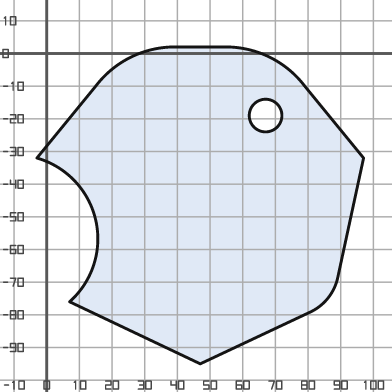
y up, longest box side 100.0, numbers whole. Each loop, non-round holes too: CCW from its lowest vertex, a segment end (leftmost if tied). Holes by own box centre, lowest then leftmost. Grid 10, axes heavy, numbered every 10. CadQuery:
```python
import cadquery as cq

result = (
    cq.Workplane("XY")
    .moveTo(47.0, -95.0)
    .lineTo(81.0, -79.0)
    .threePointArc((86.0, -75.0), (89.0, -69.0))
    .lineTo(97.0, -32.0)
    .lineTo(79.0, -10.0)
    .threePointArc((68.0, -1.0), (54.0, 2.0))
    .lineTo(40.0, 2.0)
    .threePointArc((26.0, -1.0), (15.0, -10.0))
    .lineTo(-3.0, -32.0)
    .threePointArc((15.0, -51.0), (7.0, -76.0))
    .close()
    .moveTo(67.0, -19.0)
    .circle(5.0)
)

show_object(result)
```